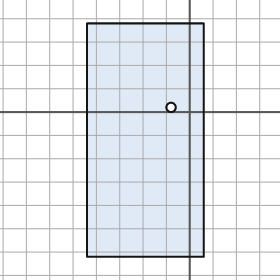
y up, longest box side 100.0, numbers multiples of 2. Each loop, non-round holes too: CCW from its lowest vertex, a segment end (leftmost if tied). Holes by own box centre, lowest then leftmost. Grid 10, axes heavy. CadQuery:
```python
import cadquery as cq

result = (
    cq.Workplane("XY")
    .moveTo(-44.0, -62.0)
    .lineTo(6.0, -62.0)
    .lineTo(6.0, 38.0)
    .lineTo(-44.0, 38.0)
    .close()
    .moveTo(-8.0, 2.0)
    .circle(2.0)
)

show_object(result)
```